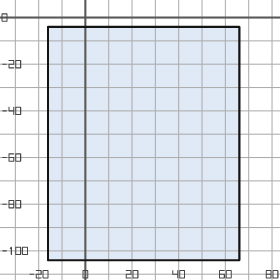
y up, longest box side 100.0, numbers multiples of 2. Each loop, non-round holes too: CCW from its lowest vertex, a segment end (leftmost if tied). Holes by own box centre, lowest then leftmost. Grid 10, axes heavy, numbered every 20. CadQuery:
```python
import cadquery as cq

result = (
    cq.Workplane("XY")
    .moveTo(-16.0, -104.0)
    .lineTo(66.0, -104.0)
    .lineTo(66.0, -4.0)
    .lineTo(-16.0, -4.0)
    .close()
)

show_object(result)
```